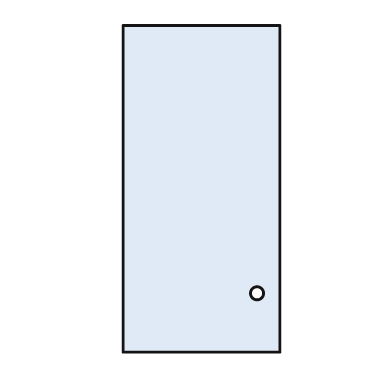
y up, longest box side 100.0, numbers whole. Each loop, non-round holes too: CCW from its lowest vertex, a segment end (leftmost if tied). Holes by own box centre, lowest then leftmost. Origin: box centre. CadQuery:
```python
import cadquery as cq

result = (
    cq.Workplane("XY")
    .moveTo(-24.0, -50.0)
    .lineTo(24.0, -50.0)
    .lineTo(24.0, 50.0)
    .lineTo(-24.0, 50.0)
    .close()
    .moveTo(17.0, -32.0)
    .circle(2.0)
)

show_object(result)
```